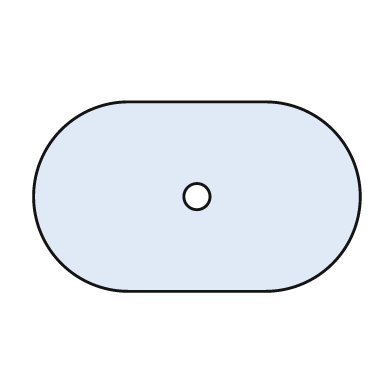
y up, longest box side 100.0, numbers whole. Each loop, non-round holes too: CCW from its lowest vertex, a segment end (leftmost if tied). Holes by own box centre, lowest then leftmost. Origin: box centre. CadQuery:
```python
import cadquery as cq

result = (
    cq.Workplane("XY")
    .moveTo(-21.0, -29.0)
    .lineTo(21.0, -29.0)
    .threePointArc((50.0, 0.0), (21.0, 29.0))
    .lineTo(-21.0, 29.0)
    .threePointArc((-50.0, 0.0), (-21.0, -29.0))
    .close()
    .moveTo(0.0, 0.0)
    .circle(4.0)
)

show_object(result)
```